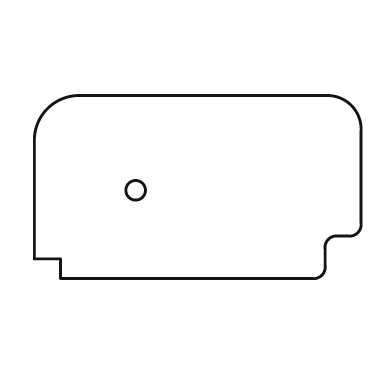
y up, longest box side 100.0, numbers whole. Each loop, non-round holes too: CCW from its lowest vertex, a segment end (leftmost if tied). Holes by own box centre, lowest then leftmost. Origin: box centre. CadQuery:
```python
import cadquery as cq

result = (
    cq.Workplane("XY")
    .moveTo(-42.0, -28.0)
    .lineTo(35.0, -28.0)
    .threePointArc((38.0, -27.0), (39.0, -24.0))
    .lineTo(39.0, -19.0)
    .threePointArc((40.0, -16.0), (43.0, -15.0))
    .lineTo(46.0, -15.0)
    .threePointArc((49.0, -14.0), (50.0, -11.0))
    .lineTo(50.0, 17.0)
    .threePointArc((47.0, 25.0), (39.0, 28.0))
    .lineTo(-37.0, 28.0)
    .threePointArc((-46.0, 24.0), (-50.0, 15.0))
    .lineTo(-50.0, -22.0)
    .lineTo(-42.0, -22.0)
    .close()
    .moveTo(-19.0, -1.0)
    .circle(3.0)
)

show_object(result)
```